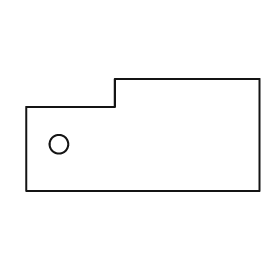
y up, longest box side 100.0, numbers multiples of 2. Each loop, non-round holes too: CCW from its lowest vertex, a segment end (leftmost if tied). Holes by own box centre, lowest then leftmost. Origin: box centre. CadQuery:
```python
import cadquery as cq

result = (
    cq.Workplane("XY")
    .moveTo(-50.0, -24.0)
    .lineTo(50.0, -24.0)
    .lineTo(50.0, 24.0)
    .lineTo(-12.0, 24.0)
    .lineTo(-12.0, 12.0)
    .lineTo(-50.0, 12.0)
    .close()
    .moveTo(-36.0, -4.0)
    .circle(4.0)
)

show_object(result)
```